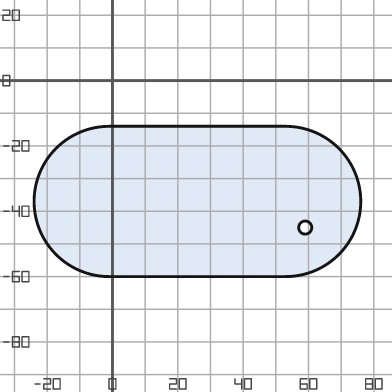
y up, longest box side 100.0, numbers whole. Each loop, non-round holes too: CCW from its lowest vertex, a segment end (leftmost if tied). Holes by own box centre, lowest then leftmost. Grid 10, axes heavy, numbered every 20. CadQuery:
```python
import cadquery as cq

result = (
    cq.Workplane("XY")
    .moveTo(-1.0, -60.0)
    .lineTo(53.0, -60.0)
    .threePointArc((76.0, -37.0), (53.0, -14.0))
    .lineTo(-1.0, -14.0)
    .threePointArc((-24.0, -37.0), (-1.0, -60.0))
    .close()
    .moveTo(59.0, -45.0)
    .circle(2.0)
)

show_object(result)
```